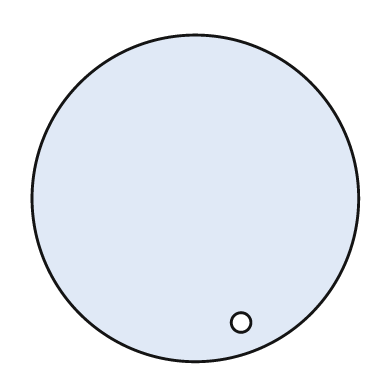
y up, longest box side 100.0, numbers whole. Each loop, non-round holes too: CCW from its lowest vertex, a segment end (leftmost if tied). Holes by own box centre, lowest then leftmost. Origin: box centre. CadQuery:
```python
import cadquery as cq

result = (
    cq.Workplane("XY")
    .moveTo(0.0, 0.0)
    .circle(50.0)
    .moveTo(14.0, -38.0)
    .circle(3.0)
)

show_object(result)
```